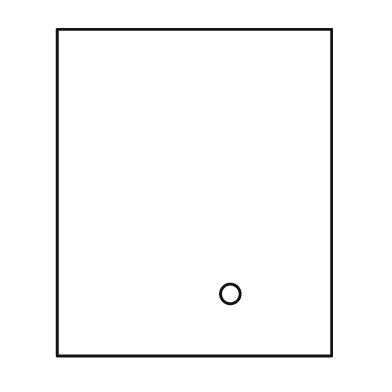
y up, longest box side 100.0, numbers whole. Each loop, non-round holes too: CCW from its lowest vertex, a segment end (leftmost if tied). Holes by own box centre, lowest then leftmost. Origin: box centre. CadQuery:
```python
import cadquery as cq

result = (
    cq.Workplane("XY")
    .moveTo(-42.0, -50.0)
    .lineTo(42.0, -50.0)
    .lineTo(42.0, 50.0)
    .lineTo(-42.0, 50.0)
    .close()
    .moveTo(11.0, -31.0)
    .circle(3.0)
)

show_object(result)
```